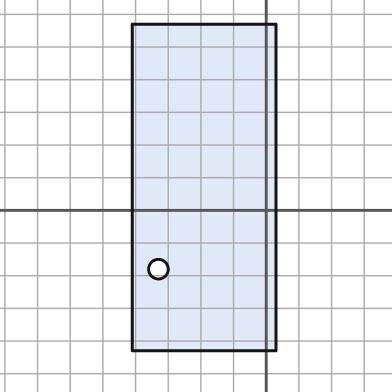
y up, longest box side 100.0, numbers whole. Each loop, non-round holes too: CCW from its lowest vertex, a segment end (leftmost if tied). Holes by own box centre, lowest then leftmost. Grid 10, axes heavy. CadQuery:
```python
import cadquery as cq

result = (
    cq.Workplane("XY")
    .moveTo(-41.0, -43.0)
    .lineTo(3.0, -43.0)
    .lineTo(3.0, 57.0)
    .lineTo(-41.0, 57.0)
    .close()
    .moveTo(-33.0, -18.0)
    .circle(3.0)
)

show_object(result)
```